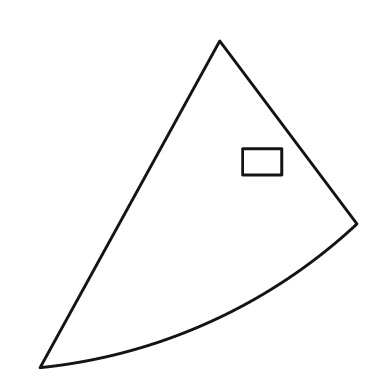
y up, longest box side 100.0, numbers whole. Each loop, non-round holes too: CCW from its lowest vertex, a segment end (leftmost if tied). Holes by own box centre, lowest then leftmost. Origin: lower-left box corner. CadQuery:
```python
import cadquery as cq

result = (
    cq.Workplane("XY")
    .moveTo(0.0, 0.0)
    .threePointArc((52.0, 14.0), (97.0, 44.0))
    .lineTo(55.0, 100.0)
    .close()
    .moveTo(62.0, 59.0)
    .lineTo(74.0, 59.0)
    .lineTo(74.0, 67.0)
    .lineTo(62.0, 67.0)
    .close()
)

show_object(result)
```